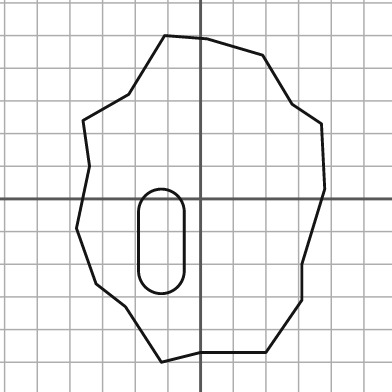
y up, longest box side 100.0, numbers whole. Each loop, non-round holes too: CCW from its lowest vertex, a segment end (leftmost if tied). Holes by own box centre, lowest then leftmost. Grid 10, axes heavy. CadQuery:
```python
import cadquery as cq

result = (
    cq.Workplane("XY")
    .moveTo(-12.0, -50.0)
    .lineTo(0.0, -47.0)
    .lineTo(20.0, -47.0)
    .lineTo(31.0, -31.0)
    .lineTo(31.0, -20.0)
    .lineTo(38.0, 3.0)
    .lineTo(37.0, 23.0)
    .lineTo(28.0, 29.0)
    .lineTo(19.0, 44.0)
    .lineTo(2.0, 49.0)
    .lineTo(-11.0, 50.0)
    .lineTo(-22.0, 32.0)
    .lineTo(-36.0, 24.0)
    .lineTo(-34.0, 10.0)
    .lineTo(-38.0, -9.0)
    .lineTo(-32.0, -26.0)
    .lineTo(-23.0, -33.0)
    .close()
    .moveTo(-19.0, -22.0)
    .threePointArc((-12.0, -29.0), (-5.0, -22.0))
    .lineTo(-5.0, -4.0)
    .threePointArc((-12.0, 3.0), (-19.0, -4.0))
    .close()
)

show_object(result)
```